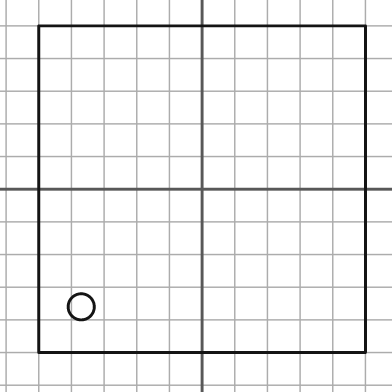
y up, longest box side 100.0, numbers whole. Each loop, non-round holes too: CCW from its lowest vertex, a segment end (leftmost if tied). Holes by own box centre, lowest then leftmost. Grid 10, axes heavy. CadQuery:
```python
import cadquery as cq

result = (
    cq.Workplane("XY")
    .moveTo(-50.0, -50.0)
    .lineTo(50.0, -50.0)
    .lineTo(50.0, 50.0)
    .lineTo(-50.0, 50.0)
    .close()
    .moveTo(-37.0, -36.0)
    .circle(4.0)
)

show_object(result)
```